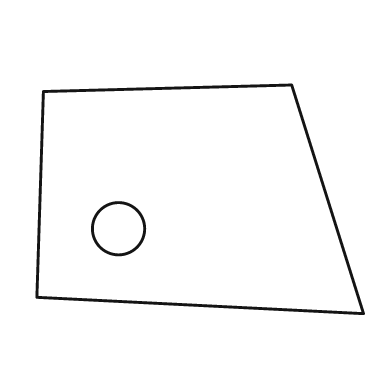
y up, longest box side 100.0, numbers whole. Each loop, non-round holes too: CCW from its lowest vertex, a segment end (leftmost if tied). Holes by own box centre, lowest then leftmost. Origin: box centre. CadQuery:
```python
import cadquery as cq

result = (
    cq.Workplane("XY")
    .moveTo(50.0, -35.0)
    .lineTo(28.0, 35.0)
    .lineTo(-48.0, 33.0)
    .lineTo(-50.0, -30.0)
    .close()
    .moveTo(-25.0, -9.0)
    .circle(8.0)
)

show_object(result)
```